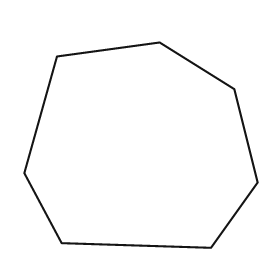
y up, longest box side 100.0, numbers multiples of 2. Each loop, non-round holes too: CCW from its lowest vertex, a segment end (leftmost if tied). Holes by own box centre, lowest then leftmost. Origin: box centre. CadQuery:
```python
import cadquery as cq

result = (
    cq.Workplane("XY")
    .moveTo(30.0, -44.0)
    .lineTo(50.0, -16.0)
    .lineTo(40.0, 24.0)
    .lineTo(8.0, 44.0)
    .lineTo(-36.0, 38.0)
    .lineTo(-50.0, -12.0)
    .lineTo(-34.0, -42.0)
    .close()
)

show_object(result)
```